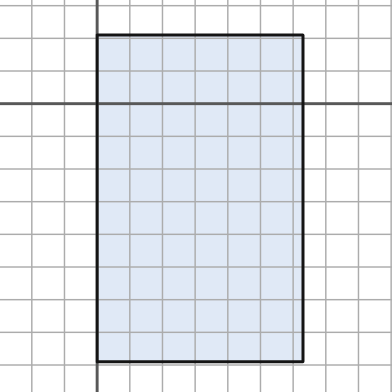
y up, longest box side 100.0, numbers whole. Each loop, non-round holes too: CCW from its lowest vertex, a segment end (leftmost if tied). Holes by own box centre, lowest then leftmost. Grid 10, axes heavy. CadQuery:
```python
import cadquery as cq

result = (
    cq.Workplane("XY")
    .moveTo(0.0, -79.0)
    .lineTo(63.0, -79.0)
    .lineTo(63.0, 21.0)
    .lineTo(0.0, 21.0)
    .close()
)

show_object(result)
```